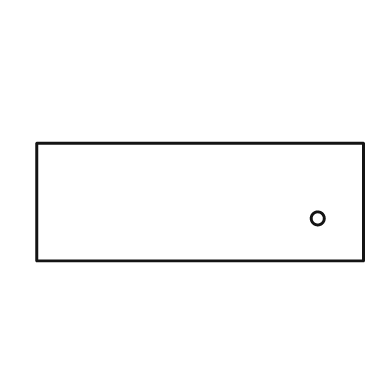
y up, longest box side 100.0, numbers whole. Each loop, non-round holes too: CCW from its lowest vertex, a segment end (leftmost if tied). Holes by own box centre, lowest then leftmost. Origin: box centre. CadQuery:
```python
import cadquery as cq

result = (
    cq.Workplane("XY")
    .moveTo(-50.0, -18.0)
    .lineTo(50.0, -18.0)
    .lineTo(50.0, 18.0)
    .lineTo(-50.0, 18.0)
    .close()
    .moveTo(36.0, -5.0)
    .circle(2.0)
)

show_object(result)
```